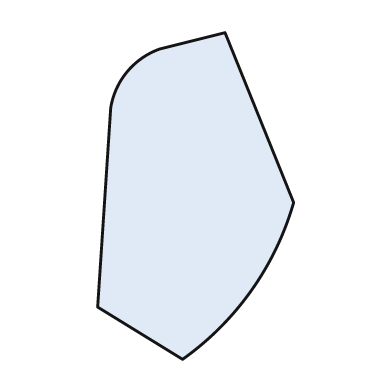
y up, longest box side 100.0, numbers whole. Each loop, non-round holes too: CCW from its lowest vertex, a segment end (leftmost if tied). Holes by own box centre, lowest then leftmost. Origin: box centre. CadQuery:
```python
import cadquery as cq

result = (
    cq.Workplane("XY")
    .moveTo(-4.0, -50.0)
    .threePointArc((17.0, -29.0), (30.0, -2.0))
    .lineTo(9.0, 50.0)
    .lineTo(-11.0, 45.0)
    .threePointArc((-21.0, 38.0), (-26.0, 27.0))
    .lineTo(-30.0, -34.0)
    .close()
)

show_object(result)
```